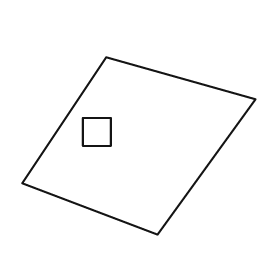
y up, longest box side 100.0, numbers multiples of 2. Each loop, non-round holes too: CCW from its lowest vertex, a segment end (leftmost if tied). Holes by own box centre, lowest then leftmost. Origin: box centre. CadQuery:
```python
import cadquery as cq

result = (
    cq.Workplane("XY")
    .moveTo(8.0, -38.0)
    .lineTo(50.0, 20.0)
    .lineTo(-14.0, 38.0)
    .lineTo(-50.0, -16.0)
    .close()
    .moveTo(-24.0, 0.0)
    .lineTo(-12.0, 0.0)
    .lineTo(-12.0, 12.0)
    .lineTo(-24.0, 12.0)
    .close()
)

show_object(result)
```